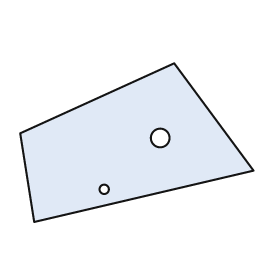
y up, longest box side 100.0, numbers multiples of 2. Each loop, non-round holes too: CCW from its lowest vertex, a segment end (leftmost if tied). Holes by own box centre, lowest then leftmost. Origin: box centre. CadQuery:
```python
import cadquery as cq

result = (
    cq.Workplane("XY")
    .moveTo(-44.0, -34.0)
    .lineTo(50.0, -12.0)
    .lineTo(16.0, 34.0)
    .lineTo(-50.0, 4.0)
    .close()
    .moveTo(-14.0, -20.0)
    .circle(2.0)
    .moveTo(10.0, 2.0)
    .circle(4.0)
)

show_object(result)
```